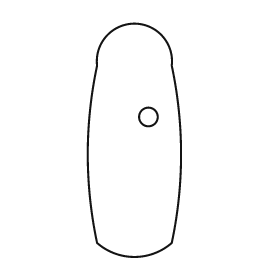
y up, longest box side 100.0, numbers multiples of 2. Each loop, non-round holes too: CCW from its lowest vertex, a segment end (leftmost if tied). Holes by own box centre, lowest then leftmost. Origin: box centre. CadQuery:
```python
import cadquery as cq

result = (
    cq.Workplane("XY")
    .moveTo(-16.0, -44.0)
    .threePointArc((0.0, -50.0), (16.0, -44.0))
    .threePointArc((20.0, -6.0), (16.0, 32.0))
    .threePointArc((0.0, 50.0), (-16.0, 32.0))
    .threePointArc((-20.0, -6.0), (-16.0, -44.0))
    .close()
    .moveTo(6.0, 10.0)
    .circle(4.0)
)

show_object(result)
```